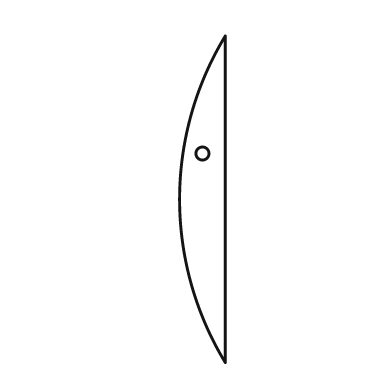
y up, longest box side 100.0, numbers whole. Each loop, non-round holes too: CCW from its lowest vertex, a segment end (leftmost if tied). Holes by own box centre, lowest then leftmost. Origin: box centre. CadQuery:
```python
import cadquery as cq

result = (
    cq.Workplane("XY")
    .moveTo(7.0, -50.0)
    .lineTo(7.0, 50.0)
    .threePointArc((-7.0, 0.0), (7.0, -50.0))
    .close()
    .moveTo(0.0, 14.0)
    .circle(2.0)
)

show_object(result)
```